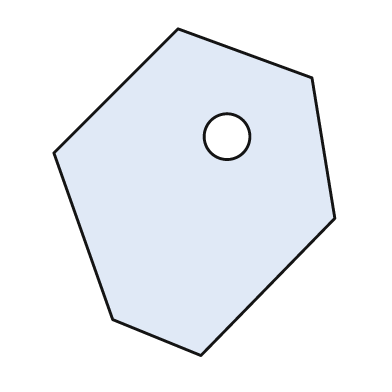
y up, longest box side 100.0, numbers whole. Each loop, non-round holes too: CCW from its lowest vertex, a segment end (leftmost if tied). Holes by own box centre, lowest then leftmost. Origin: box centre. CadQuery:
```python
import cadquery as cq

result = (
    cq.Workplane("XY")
    .moveTo(2.0, -50.0)
    .lineTo(43.0, -8.0)
    .lineTo(36.0, 35.0)
    .lineTo(-5.0, 50.0)
    .lineTo(-43.0, 12.0)
    .lineTo(-25.0, -39.0)
    .close()
    .moveTo(10.0, 17.0)
    .circle(7.0)
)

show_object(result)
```